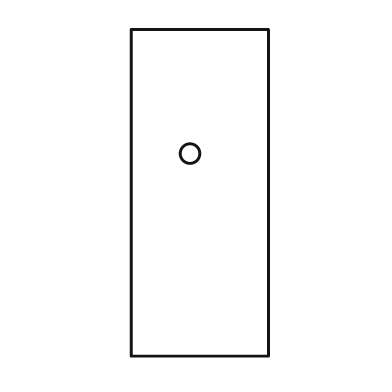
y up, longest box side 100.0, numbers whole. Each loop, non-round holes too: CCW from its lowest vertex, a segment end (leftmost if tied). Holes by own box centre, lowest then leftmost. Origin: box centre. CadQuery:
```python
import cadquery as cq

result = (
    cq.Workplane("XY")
    .moveTo(-21.0, -50.0)
    .lineTo(21.0, -50.0)
    .lineTo(21.0, 50.0)
    .lineTo(-21.0, 50.0)
    .close()
    .moveTo(-3.0, 12.0)
    .circle(3.0)
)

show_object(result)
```